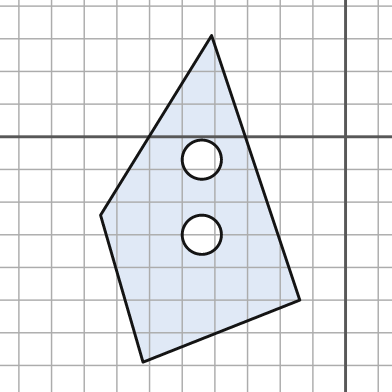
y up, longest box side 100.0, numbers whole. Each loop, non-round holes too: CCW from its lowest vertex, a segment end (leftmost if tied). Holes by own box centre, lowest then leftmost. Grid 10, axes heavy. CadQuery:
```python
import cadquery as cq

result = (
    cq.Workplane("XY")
    .moveTo(-62.0, -69.0)
    .lineTo(-14.0, -50.0)
    .lineTo(-41.0, 31.0)
    .lineTo(-75.0, -24.0)
    .close()
    .moveTo(-44.0, -30.0)
    .circle(6.0)
    .moveTo(-44.0, -7.0)
    .circle(6.0)
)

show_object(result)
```